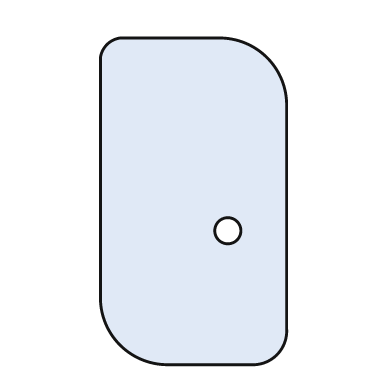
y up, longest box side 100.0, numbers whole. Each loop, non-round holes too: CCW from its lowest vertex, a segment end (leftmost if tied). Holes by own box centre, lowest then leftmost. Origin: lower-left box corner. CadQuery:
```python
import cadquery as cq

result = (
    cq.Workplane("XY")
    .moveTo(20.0, 0.0)
    .lineTo(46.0, 0.0)
    .threePointArc((54.0, 3.0), (57.0, 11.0))
    .lineTo(57.0, 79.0)
    .threePointArc((51.0, 94.0), (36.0, 100.0))
    .lineTo(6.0, 100.0)
    .threePointArc((2.0, 98.0), (0.0, 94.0))
    .lineTo(0.0, 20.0)
    .threePointArc((6.0, 6.0), (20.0, 0.0))
    .close()
    .moveTo(39.0, 41.0)
    .circle(4.0)
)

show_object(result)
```